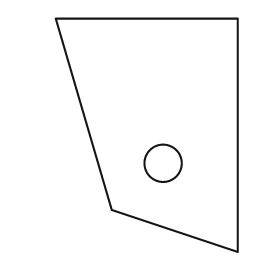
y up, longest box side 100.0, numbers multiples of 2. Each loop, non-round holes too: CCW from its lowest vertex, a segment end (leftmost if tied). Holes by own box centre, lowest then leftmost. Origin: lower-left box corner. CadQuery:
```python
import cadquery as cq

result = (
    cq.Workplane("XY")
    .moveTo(78.0, 0.0)
    .lineTo(78.0, 100.0)
    .lineTo(0.0, 100.0)
    .lineTo(24.0, 18.0)
    .close()
    .moveTo(46.0, 38.0)
    .circle(8.0)
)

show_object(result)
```